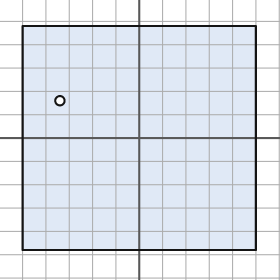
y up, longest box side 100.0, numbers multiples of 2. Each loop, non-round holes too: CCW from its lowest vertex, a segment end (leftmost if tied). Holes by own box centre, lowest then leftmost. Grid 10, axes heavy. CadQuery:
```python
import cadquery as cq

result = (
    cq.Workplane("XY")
    .moveTo(-50.0, -48.0)
    .lineTo(50.0, -48.0)
    .lineTo(50.0, 48.0)
    .lineTo(-50.0, 48.0)
    .close()
    .moveTo(-34.0, 16.0)
    .circle(2.0)
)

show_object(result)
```